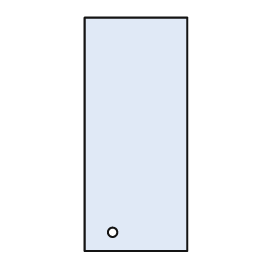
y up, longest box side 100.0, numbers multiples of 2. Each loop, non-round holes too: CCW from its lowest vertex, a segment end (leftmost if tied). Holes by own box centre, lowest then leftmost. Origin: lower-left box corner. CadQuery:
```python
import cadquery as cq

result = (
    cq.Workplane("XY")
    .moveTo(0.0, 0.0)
    .lineTo(44.0, 0.0)
    .lineTo(44.0, 100.0)
    .lineTo(0.0, 100.0)
    .close()
    .moveTo(12.0, 8.0)
    .circle(2.0)
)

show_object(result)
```